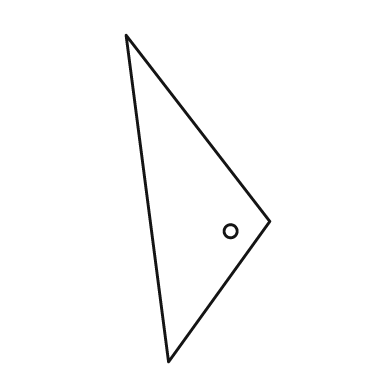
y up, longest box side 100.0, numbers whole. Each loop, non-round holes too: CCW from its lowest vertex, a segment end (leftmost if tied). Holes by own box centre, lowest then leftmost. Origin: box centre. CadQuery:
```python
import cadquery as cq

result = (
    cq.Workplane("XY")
    .moveTo(-9.0, -50.0)
    .lineTo(22.0, -7.0)
    .lineTo(-22.0, 50.0)
    .close()
    .moveTo(10.0, -10.0)
    .circle(2.0)
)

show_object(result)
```